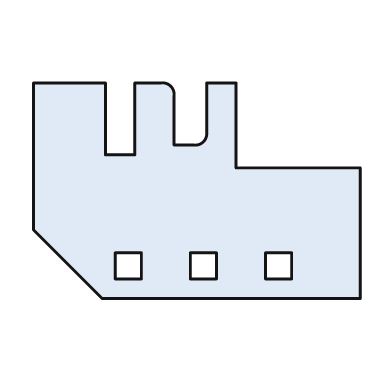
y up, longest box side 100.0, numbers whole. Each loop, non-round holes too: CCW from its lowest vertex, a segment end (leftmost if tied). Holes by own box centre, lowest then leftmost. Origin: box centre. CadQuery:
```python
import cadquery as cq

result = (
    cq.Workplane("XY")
    .moveTo(-29.0, -33.0)
    .lineTo(50.0, -33.0)
    .lineTo(50.0, 7.0)
    .lineTo(12.0, 7.0)
    .lineTo(12.0, 33.0)
    .lineTo(3.0, 33.0)
    .lineTo(3.0, 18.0)
    .threePointArc((2.0, 15.0), (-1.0, 14.0))
    .lineTo(-7.0, 14.0)
    .lineTo(-7.0, 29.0)
    .threePointArc((-8.0, 32.0), (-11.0, 33.0))
    .lineTo(-19.0, 33.0)
    .lineTo(-19.0, 11.0)
    .lineTo(-28.0, 11.0)
    .lineTo(-28.0, 33.0)
    .lineTo(-50.0, 33.0)
    .lineTo(-50.0, -12.0)
    .close()
    .moveTo(-25.0, -27.0)
    .lineTo(-17.0, -27.0)
    .lineTo(-17.0, -19.0)
    .lineTo(-25.0, -19.0)
    .close()
    .moveTo(-2.0, -27.0)
    .lineTo(6.0, -27.0)
    .lineTo(6.0, -19.0)
    .lineTo(-2.0, -19.0)
    .close()
    .moveTo(21.0, -27.0)
    .lineTo(29.0, -27.0)
    .lineTo(29.0, -19.0)
    .lineTo(21.0, -19.0)
    .close()
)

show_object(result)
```